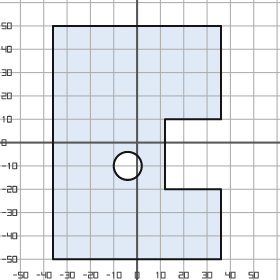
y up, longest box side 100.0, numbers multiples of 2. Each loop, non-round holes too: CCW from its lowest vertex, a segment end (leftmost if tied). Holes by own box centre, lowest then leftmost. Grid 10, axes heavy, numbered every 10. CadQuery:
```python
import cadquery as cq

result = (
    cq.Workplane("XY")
    .moveTo(-36.0, -50.0)
    .lineTo(36.0, -50.0)
    .lineTo(36.0, -20.0)
    .lineTo(12.0, -20.0)
    .lineTo(12.0, 10.0)
    .lineTo(36.0, 10.0)
    .lineTo(36.0, 50.0)
    .lineTo(-36.0, 50.0)
    .close()
    .moveTo(-4.0, -10.0)
    .circle(6.0)
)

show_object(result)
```